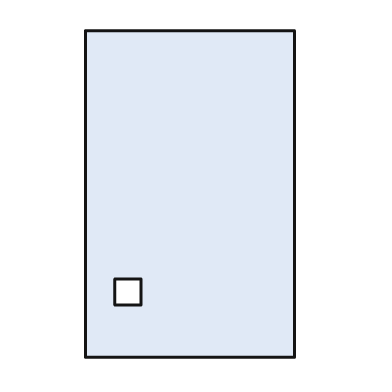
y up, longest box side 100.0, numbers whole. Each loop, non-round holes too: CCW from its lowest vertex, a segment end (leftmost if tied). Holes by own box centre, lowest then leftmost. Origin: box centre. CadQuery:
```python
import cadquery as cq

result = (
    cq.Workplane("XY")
    .moveTo(-32.0, -50.0)
    .lineTo(32.0, -50.0)
    .lineTo(32.0, 50.0)
    .lineTo(-32.0, 50.0)
    .close()
    .moveTo(-23.0, -34.0)
    .lineTo(-15.0, -34.0)
    .lineTo(-15.0, -26.0)
    .lineTo(-23.0, -26.0)
    .close()
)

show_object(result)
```